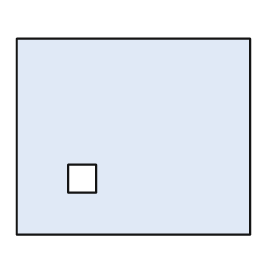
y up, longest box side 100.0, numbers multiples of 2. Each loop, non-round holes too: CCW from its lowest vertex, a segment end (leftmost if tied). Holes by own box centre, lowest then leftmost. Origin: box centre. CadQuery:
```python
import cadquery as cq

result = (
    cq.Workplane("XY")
    .moveTo(-50.0, -42.0)
    .lineTo(50.0, -42.0)
    .lineTo(50.0, 42.0)
    .lineTo(-50.0, 42.0)
    .close()
    .moveTo(-28.0, -24.0)
    .lineTo(-16.0, -24.0)
    .lineTo(-16.0, -12.0)
    .lineTo(-28.0, -12.0)
    .close()
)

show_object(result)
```